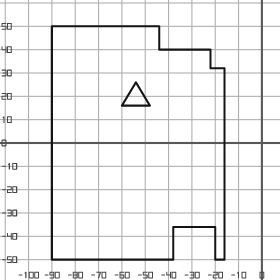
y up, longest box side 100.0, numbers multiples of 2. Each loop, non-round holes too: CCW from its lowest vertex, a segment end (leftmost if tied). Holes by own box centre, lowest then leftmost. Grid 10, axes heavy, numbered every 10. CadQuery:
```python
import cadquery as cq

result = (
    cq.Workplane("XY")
    .moveTo(-90.0, -50.0)
    .lineTo(-38.0, -50.0)
    .lineTo(-38.0, -36.0)
    .lineTo(-20.0, -36.0)
    .lineTo(-20.0, -50.0)
    .lineTo(-16.0, -50.0)
    .lineTo(-16.0, 32.0)
    .lineTo(-22.0, 32.0)
    .lineTo(-22.0, 40.0)
    .lineTo(-44.0, 40.0)
    .lineTo(-44.0, 50.0)
    .lineTo(-90.0, 50.0)
    .close()
    .moveTo(-60.0, 16.0)
    .lineTo(-48.0, 16.0)
    .lineTo(-54.0, 26.0)
    .close()
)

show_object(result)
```